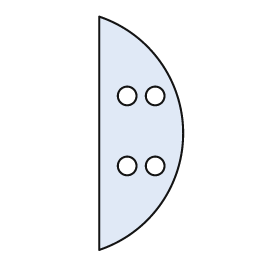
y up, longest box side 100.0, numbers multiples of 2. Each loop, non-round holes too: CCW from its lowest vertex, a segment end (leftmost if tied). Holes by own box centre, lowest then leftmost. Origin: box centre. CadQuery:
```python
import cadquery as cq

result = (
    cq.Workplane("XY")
    .moveTo(-18.0, -50.0)
    .threePointArc((18.0, 0.0), (-18.0, 50.0))
    .close()
    .moveTo(-6.0, -14.0)
    .circle(4.0)
    .moveTo(6.0, -14.0)
    .circle(4.0)
    .moveTo(-6.0, 16.0)
    .circle(4.0)
    .moveTo(6.0, 16.0)
    .circle(4.0)
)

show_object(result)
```